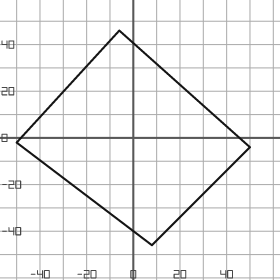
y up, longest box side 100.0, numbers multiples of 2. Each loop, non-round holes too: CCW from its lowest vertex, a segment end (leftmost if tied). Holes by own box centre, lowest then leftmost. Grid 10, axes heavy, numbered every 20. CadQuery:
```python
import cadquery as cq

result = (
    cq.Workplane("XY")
    .moveTo(8.0, -46.0)
    .lineTo(50.0, -4.0)
    .lineTo(-6.0, 46.0)
    .lineTo(-50.0, -2.0)
    .close()
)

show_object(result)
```